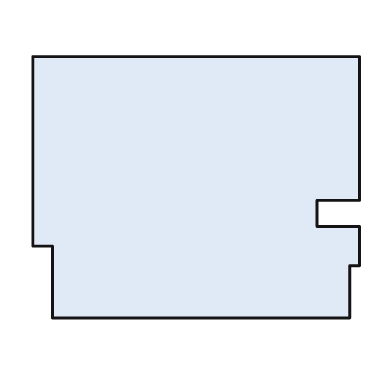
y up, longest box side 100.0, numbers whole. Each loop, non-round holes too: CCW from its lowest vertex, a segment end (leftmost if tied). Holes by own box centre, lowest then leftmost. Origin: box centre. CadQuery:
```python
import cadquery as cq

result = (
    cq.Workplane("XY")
    .moveTo(-44.0, -40.0)
    .lineTo(47.0, -40.0)
    .lineTo(47.0, -24.0)
    .lineTo(50.0, -24.0)
    .lineTo(50.0, -12.0)
    .lineTo(37.0, -12.0)
    .lineTo(37.0, -4.0)
    .lineTo(50.0, -4.0)
    .lineTo(50.0, 40.0)
    .lineTo(-50.0, 40.0)
    .lineTo(-50.0, -18.0)
    .lineTo(-44.0, -18.0)
    .close()
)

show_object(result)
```